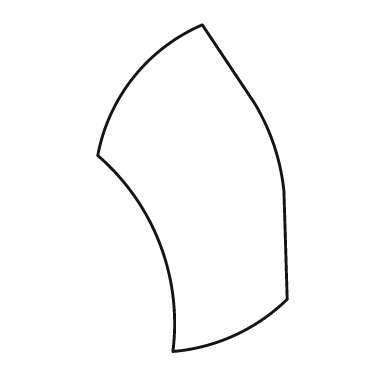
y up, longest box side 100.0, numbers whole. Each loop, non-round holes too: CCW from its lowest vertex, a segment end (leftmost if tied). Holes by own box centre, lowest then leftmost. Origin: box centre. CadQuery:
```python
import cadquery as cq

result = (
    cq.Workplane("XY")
    .moveTo(-6.0, -50.0)
    .threePointArc((13.0, -45.0), (29.0, -34.0))
    .lineTo(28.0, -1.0)
    .threePointArc((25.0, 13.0), (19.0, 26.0))
    .lineTo(3.0, 50.0)
    .threePointArc((-18.0, 34.0), (-29.0, 10.0))
    .threePointArc((-10.0, -17.0), (-6.0, -50.0))
    .close()
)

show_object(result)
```